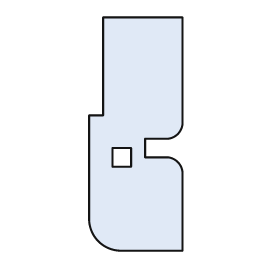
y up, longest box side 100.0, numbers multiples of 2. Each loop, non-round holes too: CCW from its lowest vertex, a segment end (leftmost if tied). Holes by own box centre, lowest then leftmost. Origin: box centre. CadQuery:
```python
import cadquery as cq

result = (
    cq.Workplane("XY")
    .moveTo(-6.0, -50.0)
    .lineTo(20.0, -50.0)
    .lineTo(20.0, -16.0)
    .threePointArc((18.0, -12.0), (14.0, -10.0))
    .lineTo(4.0, -10.0)
    .lineTo(4.0, -2.0)
    .lineTo(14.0, -2.0)
    .threePointArc((18.0, 0.0), (20.0, 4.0))
    .lineTo(20.0, 50.0)
    .lineTo(-14.0, 50.0)
    .lineTo(-14.0, 8.0)
    .lineTo(-20.0, 8.0)
    .lineTo(-20.0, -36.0)
    .threePointArc((-16.0, -46.0), (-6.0, -50.0))
    .close()
    .moveTo(-10.0, -14.0)
    .lineTo(-2.0, -14.0)
    .lineTo(-2.0, -6.0)
    .lineTo(-10.0, -6.0)
    .close()
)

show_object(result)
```